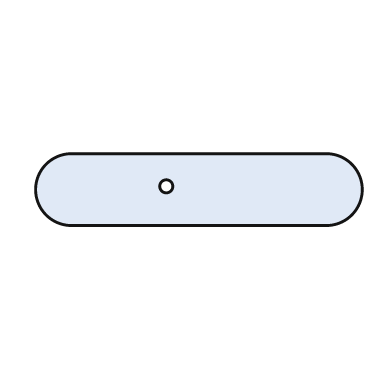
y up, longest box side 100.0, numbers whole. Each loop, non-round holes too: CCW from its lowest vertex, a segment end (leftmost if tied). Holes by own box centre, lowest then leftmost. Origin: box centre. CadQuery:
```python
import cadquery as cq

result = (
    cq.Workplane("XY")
    .moveTo(-39.0, -11.0)
    .lineTo(39.0, -11.0)
    .threePointArc((50.0, 0.0), (39.0, 11.0))
    .lineTo(-39.0, 11.0)
    .threePointArc((-50.0, 0.0), (-39.0, -11.0))
    .close()
    .moveTo(-10.0, 1.0)
    .circle(2.0)
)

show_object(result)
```